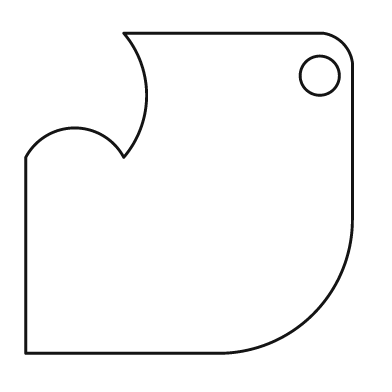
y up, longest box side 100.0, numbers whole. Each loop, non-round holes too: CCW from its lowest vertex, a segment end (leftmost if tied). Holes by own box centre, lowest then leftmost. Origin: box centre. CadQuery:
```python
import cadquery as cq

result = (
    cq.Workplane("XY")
    .moveTo(-50.0, -49.0)
    .lineTo(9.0, -49.0)
    .threePointArc((38.0, -37.0), (50.0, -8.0))
    .lineTo(50.0, 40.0)
    .threePointArc((47.0, 46.0), (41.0, 49.0))
    .lineTo(-20.0, 49.0)
    .threePointArc((-13.0, 30.0), (-20.0, 11.0))
    .threePointArc((-35.0, 20.0), (-50.0, 11.0))
    .close()
    .moveTo(40.0, 36.0)
    .circle(6.0)
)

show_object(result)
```